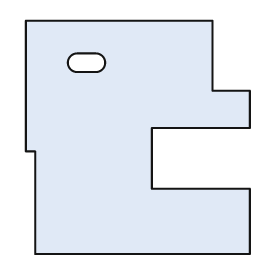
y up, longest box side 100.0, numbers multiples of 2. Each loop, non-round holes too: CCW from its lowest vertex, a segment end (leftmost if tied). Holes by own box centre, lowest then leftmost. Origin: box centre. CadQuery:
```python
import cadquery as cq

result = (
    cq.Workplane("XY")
    .moveTo(-44.0, -50.0)
    .lineTo(48.0, -50.0)
    .lineTo(48.0, -22.0)
    .lineTo(6.0, -22.0)
    .lineTo(6.0, 4.0)
    .lineTo(48.0, 4.0)
    .lineTo(48.0, 20.0)
    .lineTo(32.0, 20.0)
    .lineTo(32.0, 50.0)
    .lineTo(-48.0, 50.0)
    .lineTo(-48.0, -6.0)
    .lineTo(-44.0, -6.0)
    .close()
    .moveTo(-26.0, 28.0)
    .lineTo(-18.0, 28.0)
    .threePointArc((-14.0, 32.0), (-18.0, 36.0))
    .lineTo(-26.0, 36.0)
    .threePointArc((-30.0, 32.0), (-26.0, 28.0))
    .close()
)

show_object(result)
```